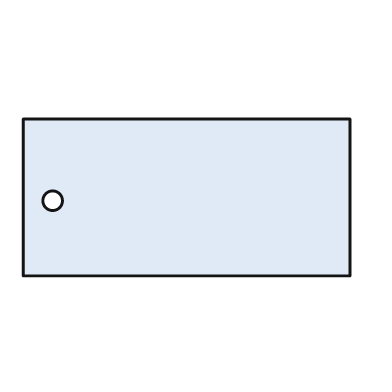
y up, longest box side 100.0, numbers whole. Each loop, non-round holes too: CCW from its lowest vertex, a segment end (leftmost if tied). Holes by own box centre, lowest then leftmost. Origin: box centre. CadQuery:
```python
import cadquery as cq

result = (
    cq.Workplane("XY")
    .moveTo(-50.0, -24.0)
    .lineTo(50.0, -24.0)
    .lineTo(50.0, 24.0)
    .lineTo(-50.0, 24.0)
    .close()
    .moveTo(-41.0, -1.0)
    .circle(3.0)
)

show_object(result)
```